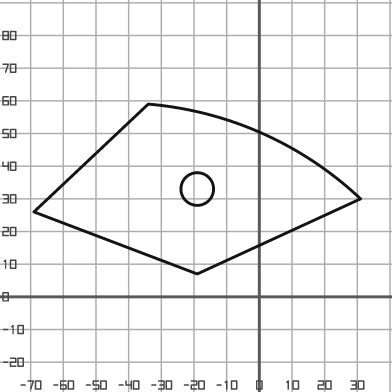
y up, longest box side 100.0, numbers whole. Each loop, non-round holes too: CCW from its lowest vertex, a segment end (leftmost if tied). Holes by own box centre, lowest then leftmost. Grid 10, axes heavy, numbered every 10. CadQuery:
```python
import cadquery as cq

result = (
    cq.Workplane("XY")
    .moveTo(-19.0, 7.0)
    .lineTo(31.0, 30.0)
    .threePointArc((1.0, 50.0), (-34.0, 59.0))
    .lineTo(-69.0, 26.0)
    .close()
    .moveTo(-19.0, 33.0)
    .circle(5.0)
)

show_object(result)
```